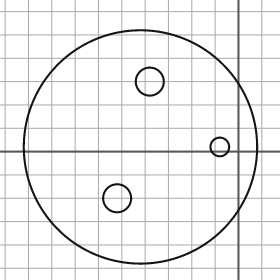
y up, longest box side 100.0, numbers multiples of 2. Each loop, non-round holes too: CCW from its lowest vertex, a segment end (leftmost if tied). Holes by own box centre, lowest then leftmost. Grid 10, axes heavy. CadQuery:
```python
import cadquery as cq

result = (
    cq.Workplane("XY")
    .moveTo(-42.0, 2.0)
    .circle(50.0)
    .moveTo(-52.0, -20.0)
    .circle(6.0)
    .moveTo(-8.0, 2.0)
    .circle(4.0)
    .moveTo(-38.0, 30.0)
    .circle(6.0)
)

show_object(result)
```